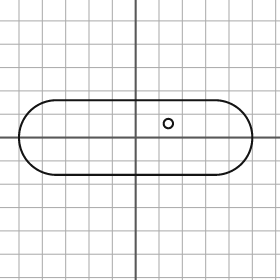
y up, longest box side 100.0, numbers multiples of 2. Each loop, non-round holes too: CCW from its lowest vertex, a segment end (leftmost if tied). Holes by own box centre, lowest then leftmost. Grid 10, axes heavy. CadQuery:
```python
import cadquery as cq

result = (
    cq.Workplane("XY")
    .moveTo(-34.0, -16.0)
    .lineTo(34.0, -16.0)
    .threePointArc((50.0, 0.0), (34.0, 16.0))
    .lineTo(-34.0, 16.0)
    .threePointArc((-50.0, 0.0), (-34.0, -16.0))
    .close()
    .moveTo(14.0, 6.0)
    .circle(2.0)
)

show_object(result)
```